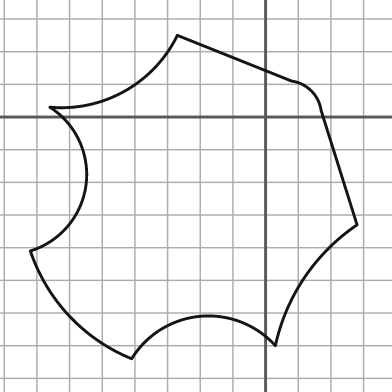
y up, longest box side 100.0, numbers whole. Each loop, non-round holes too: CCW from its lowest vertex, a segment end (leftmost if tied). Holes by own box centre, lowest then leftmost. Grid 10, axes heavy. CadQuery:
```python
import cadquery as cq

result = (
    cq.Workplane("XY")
    .moveTo(-41.0, -74.0)
    .threePointArc((-20.0, -61.0), (3.0, -70.0))
    .threePointArc((12.0, -49.0), (28.0, -33.0))
    .lineTo(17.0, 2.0)
    .threePointArc((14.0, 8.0), (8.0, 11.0))
    .lineTo(-27.0, 25.0)
    .threePointArc((-43.0, 8.0), (-66.0, 3.0))
    .threePointArc((-55.0, -21.0), (-72.0, -41.0))
    .threePointArc((-60.0, -61.0), (-41.0, -74.0))
    .close()
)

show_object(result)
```